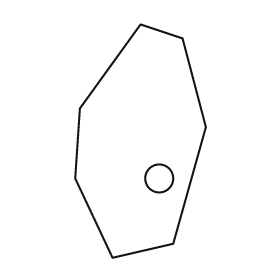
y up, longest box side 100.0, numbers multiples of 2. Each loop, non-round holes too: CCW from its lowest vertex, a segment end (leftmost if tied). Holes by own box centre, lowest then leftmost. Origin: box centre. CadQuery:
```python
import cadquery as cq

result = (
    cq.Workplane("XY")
    .moveTo(-12.0, -50.0)
    .lineTo(14.0, -44.0)
    .lineTo(28.0, 6.0)
    .lineTo(18.0, 44.0)
    .lineTo(0.0, 50.0)
    .lineTo(-26.0, 14.0)
    .lineTo(-28.0, -16.0)
    .close()
    .moveTo(8.0, -16.0)
    .circle(6.0)
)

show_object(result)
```